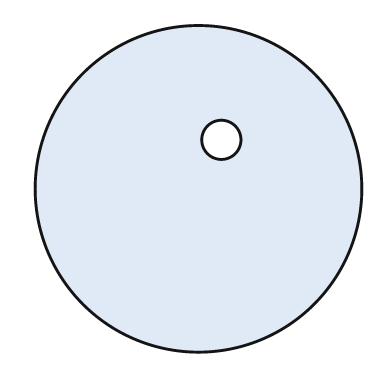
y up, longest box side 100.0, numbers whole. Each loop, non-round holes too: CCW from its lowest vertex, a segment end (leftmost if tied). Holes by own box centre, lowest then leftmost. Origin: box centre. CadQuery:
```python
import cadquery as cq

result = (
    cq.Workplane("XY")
    .moveTo(0.0, 0.0)
    .circle(50.0)
    .moveTo(7.0, 15.0)
    .circle(6.0)
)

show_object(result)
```